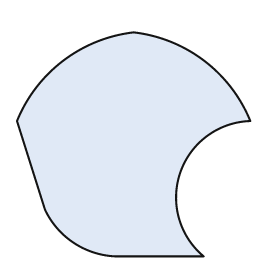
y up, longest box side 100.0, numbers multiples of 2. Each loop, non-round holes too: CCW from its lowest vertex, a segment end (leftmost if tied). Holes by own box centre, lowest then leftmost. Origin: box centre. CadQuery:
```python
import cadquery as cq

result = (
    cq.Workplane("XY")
    .moveTo(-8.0, -48.0)
    .lineTo(30.0, -48.0)
    .threePointArc((20.0, -12.0), (50.0, 10.0))
    .threePointArc((30.0, 36.0), (0.0, 48.0))
    .threePointArc((-30.0, 36.0), (-50.0, 10.0))
    .lineTo(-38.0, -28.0)
    .threePointArc((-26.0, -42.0), (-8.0, -48.0))
    .close()
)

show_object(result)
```